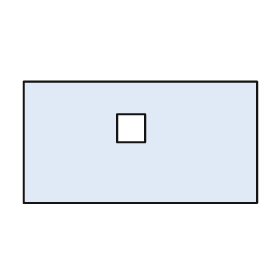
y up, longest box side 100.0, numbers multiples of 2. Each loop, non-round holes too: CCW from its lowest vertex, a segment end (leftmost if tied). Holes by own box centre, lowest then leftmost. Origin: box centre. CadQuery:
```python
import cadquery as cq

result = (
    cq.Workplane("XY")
    .moveTo(-50.0, -26.0)
    .lineTo(50.0, -26.0)
    .lineTo(50.0, 26.0)
    .lineTo(-50.0, 26.0)
    .close()
    .moveTo(-10.0, 0.0)
    .lineTo(2.0, 0.0)
    .lineTo(2.0, 12.0)
    .lineTo(-10.0, 12.0)
    .close()
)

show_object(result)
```